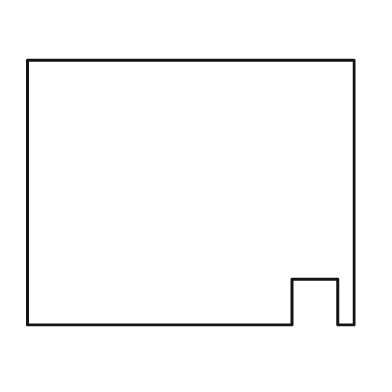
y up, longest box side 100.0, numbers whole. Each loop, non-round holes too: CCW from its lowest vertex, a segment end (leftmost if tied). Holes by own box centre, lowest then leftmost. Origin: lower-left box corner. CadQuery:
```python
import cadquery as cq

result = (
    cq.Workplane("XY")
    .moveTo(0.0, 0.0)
    .lineTo(81.0, 0.0)
    .lineTo(81.0, 14.0)
    .lineTo(95.0, 14.0)
    .lineTo(95.0, 0.0)
    .lineTo(100.0, 0.0)
    .lineTo(100.0, 81.0)
    .lineTo(0.0, 81.0)
    .close()
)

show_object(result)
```